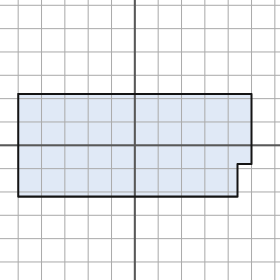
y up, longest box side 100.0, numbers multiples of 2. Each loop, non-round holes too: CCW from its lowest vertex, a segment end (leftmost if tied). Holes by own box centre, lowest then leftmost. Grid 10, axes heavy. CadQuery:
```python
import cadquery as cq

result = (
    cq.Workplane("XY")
    .moveTo(-50.0, -22.0)
    .lineTo(44.0, -22.0)
    .lineTo(44.0, -8.0)
    .lineTo(50.0, -8.0)
    .lineTo(50.0, 22.0)
    .lineTo(-50.0, 22.0)
    .close()
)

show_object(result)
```